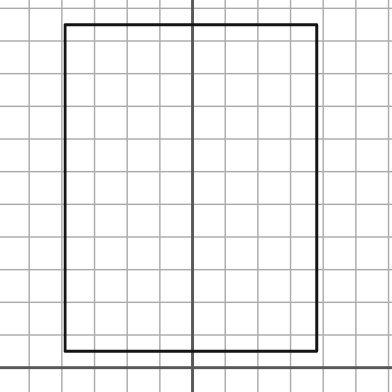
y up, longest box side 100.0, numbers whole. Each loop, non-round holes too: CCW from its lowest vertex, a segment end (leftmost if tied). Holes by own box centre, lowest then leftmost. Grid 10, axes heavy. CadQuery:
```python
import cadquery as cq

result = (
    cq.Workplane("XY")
    .moveTo(-39.0, 5.0)
    .lineTo(38.0, 5.0)
    .lineTo(38.0, 105.0)
    .lineTo(-39.0, 105.0)
    .close()
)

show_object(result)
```